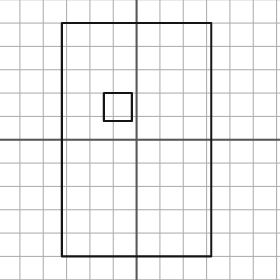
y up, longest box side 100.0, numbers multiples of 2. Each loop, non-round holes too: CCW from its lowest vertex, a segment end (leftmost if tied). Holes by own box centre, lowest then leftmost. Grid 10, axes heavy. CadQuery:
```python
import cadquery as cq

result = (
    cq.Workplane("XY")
    .moveTo(-32.0, -50.0)
    .lineTo(32.0, -50.0)
    .lineTo(32.0, 50.0)
    .lineTo(-32.0, 50.0)
    .close()
    .moveTo(-14.0, 8.0)
    .lineTo(-2.0, 8.0)
    .lineTo(-2.0, 20.0)
    .lineTo(-14.0, 20.0)
    .close()
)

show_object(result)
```